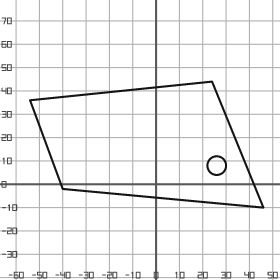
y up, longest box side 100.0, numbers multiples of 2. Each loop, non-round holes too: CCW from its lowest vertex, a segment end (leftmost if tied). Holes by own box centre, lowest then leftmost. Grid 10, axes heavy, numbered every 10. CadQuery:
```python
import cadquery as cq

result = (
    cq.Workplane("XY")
    .moveTo(46.0, -10.0)
    .lineTo(24.0, 44.0)
    .lineTo(-54.0, 36.0)
    .lineTo(-40.0, -2.0)
    .close()
    .moveTo(26.0, 8.0)
    .circle(4.0)
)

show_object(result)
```